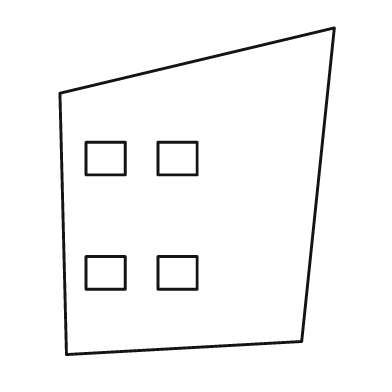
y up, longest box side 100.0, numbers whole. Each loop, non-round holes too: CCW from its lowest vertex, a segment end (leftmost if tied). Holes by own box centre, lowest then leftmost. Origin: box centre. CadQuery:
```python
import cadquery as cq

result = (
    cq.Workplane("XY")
    .moveTo(-40.0, -50.0)
    .lineTo(32.0, -46.0)
    .lineTo(42.0, 50.0)
    .lineTo(-42.0, 30.0)
    .close()
    .moveTo(-34.0, -30.0)
    .lineTo(-22.0, -30.0)
    .lineTo(-22.0, -20.0)
    .lineTo(-34.0, -20.0)
    .close()
    .moveTo(-12.0, -30.0)
    .lineTo(0.0, -30.0)
    .lineTo(0.0, -20.0)
    .lineTo(-12.0, -20.0)
    .close()
    .moveTo(-34.0, 5.0)
    .lineTo(-22.0, 5.0)
    .lineTo(-22.0, 15.0)
    .lineTo(-34.0, 15.0)
    .close()
    .moveTo(-12.0, 5.0)
    .lineTo(0.0, 5.0)
    .lineTo(0.0, 15.0)
    .lineTo(-12.0, 15.0)
    .close()
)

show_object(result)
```